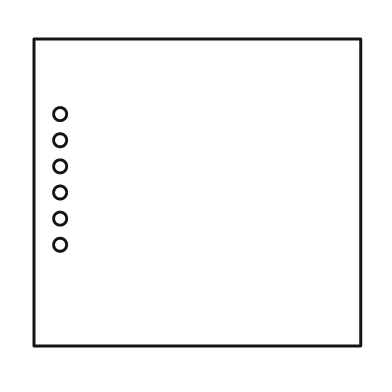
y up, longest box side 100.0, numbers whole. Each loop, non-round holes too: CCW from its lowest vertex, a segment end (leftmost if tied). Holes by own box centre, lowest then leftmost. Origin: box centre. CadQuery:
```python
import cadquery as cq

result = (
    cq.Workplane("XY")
    .moveTo(-50.0, -47.0)
    .lineTo(50.0, -47.0)
    .lineTo(50.0, 47.0)
    .lineTo(-50.0, 47.0)
    .close()
    .moveTo(-42.0, -16.0)
    .circle(2.0)
    .moveTo(-42.0, -8.0)
    .circle(2.0)
    .moveTo(-42.0, 0.0)
    .circle(2.0)
    .moveTo(-42.0, 8.0)
    .circle(2.0)
    .moveTo(-42.0, 16.0)
    .circle(2.0)
    .moveTo(-42.0, 24.0)
    .circle(2.0)
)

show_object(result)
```